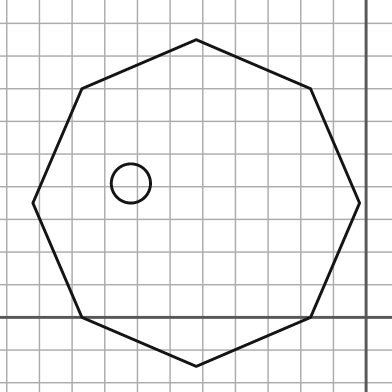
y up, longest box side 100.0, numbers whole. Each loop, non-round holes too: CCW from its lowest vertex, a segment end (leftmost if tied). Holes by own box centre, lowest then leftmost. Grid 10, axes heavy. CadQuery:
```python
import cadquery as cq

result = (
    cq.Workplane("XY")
    .moveTo(-52.0, -15.0)
    .lineTo(-17.0, 0.0)
    .lineTo(-2.0, 35.0)
    .lineTo(-17.0, 70.0)
    .lineTo(-52.0, 85.0)
    .lineTo(-87.0, 70.0)
    .lineTo(-102.0, 35.0)
    .lineTo(-87.0, 0.0)
    .close()
    .moveTo(-72.0, 41.0)
    .circle(6.0)
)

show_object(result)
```